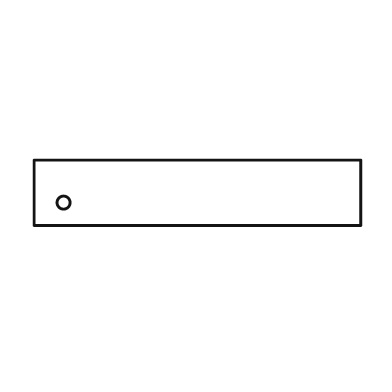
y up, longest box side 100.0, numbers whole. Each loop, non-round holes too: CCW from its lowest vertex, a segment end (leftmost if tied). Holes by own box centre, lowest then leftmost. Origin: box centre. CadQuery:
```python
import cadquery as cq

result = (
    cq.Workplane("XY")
    .moveTo(-50.0, -10.0)
    .lineTo(50.0, -10.0)
    .lineTo(50.0, 10.0)
    .lineTo(-50.0, 10.0)
    .close()
    .moveTo(-41.0, -3.0)
    .circle(2.0)
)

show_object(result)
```